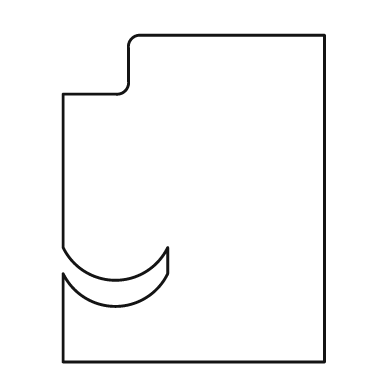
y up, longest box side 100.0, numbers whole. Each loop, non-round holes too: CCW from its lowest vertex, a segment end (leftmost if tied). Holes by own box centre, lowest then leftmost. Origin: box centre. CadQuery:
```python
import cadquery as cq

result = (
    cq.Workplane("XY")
    .moveTo(-40.0, -50.0)
    .lineTo(40.0, -50.0)
    .lineTo(40.0, 50.0)
    .lineTo(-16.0, 50.0)
    .threePointArc((-19.0, 49.0), (-20.0, 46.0))
    .lineTo(-20.0, 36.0)
    .threePointArc((-21.0, 33.0), (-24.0, 32.0))
    .lineTo(-40.0, 32.0)
    .lineTo(-40.0, -15.0)
    .threePointArc((-24.0, -25.0), (-8.0, -15.0))
    .lineTo(-8.0, -23.0)
    .threePointArc((-24.0, -33.0), (-40.0, -23.0))
    .close()
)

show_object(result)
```